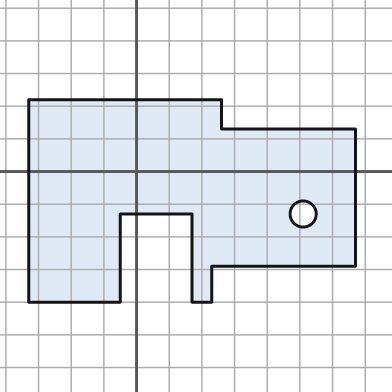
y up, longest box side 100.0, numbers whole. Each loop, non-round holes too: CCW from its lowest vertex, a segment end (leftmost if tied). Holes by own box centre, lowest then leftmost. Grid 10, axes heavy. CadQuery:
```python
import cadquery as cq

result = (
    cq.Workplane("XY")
    .moveTo(-33.0, -40.0)
    .lineTo(-5.0, -40.0)
    .lineTo(-5.0, -13.0)
    .lineTo(17.0, -13.0)
    .lineTo(17.0, -40.0)
    .lineTo(23.0, -40.0)
    .lineTo(23.0, -29.0)
    .lineTo(67.0, -29.0)
    .lineTo(67.0, 13.0)
    .lineTo(26.0, 13.0)
    .lineTo(26.0, 22.0)
    .lineTo(-33.0, 22.0)
    .close()
    .moveTo(51.0, -13.0)
    .circle(4.0)
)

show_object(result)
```